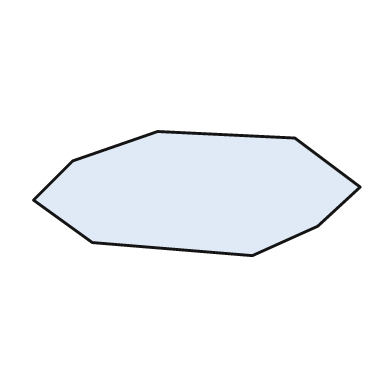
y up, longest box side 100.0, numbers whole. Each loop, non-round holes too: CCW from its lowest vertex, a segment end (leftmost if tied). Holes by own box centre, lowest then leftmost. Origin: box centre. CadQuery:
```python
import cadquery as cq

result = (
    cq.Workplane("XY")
    .moveTo(17.0, -19.0)
    .lineTo(37.0, -10.0)
    .lineTo(50.0, 2.0)
    .lineTo(30.0, 17.0)
    .lineTo(-12.0, 19.0)
    .lineTo(-38.0, 10.0)
    .lineTo(-50.0, -2.0)
    .lineTo(-32.0, -15.0)
    .close()
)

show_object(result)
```